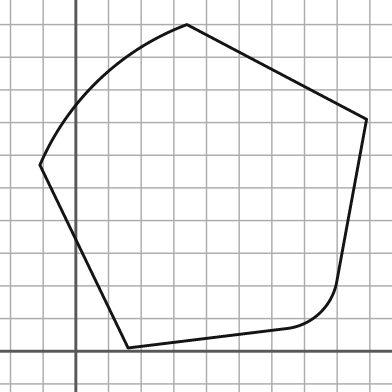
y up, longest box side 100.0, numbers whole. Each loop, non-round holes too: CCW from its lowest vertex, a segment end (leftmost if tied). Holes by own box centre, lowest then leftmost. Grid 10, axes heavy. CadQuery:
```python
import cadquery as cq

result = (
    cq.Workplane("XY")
    .moveTo(16.0, 1.0)
    .lineTo(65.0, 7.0)
    .threePointArc((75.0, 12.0), (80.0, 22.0))
    .lineTo(89.0, 71.0)
    .lineTo(34.0, 100.0)
    .threePointArc((7.0, 83.0), (-11.0, 57.0))
    .close()
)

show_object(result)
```